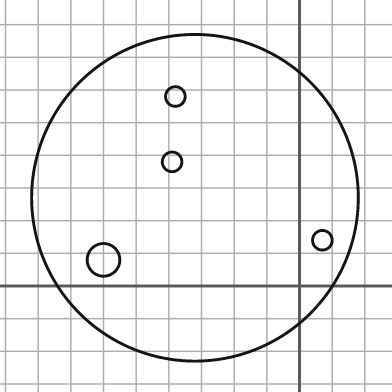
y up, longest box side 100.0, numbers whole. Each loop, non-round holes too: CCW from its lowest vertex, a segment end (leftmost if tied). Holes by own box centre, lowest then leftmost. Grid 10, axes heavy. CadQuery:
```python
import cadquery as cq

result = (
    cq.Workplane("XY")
    .moveTo(-32.0, 27.0)
    .circle(50.0)
    .moveTo(-60.0, 8.0)
    .circle(5.0)
    .moveTo(7.0, 14.0)
    .circle(3.0)
    .moveTo(-39.0, 38.0)
    .circle(3.0)
    .moveTo(-38.0, 58.0)
    .circle(3.0)
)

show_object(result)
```